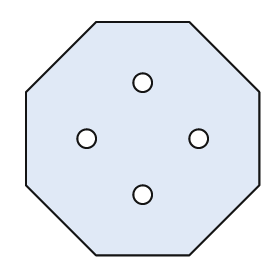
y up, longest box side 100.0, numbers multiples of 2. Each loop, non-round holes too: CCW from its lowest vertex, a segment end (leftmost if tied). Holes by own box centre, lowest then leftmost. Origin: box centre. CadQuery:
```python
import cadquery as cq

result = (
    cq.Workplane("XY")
    .moveTo(-20.0, -50.0)
    .lineTo(20.0, -50.0)
    .lineTo(50.0, -20.0)
    .lineTo(50.0, 20.0)
    .lineTo(20.0, 50.0)
    .lineTo(-20.0, 50.0)
    .lineTo(-50.0, 20.0)
    .lineTo(-50.0, -20.0)
    .close()
    .moveTo(0.0, -24.0)
    .circle(4.0)
    .moveTo(-24.0, 0.0)
    .circle(4.0)
    .moveTo(24.0, 0.0)
    .circle(4.0)
    .moveTo(0.0, 24.0)
    .circle(4.0)
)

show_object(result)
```